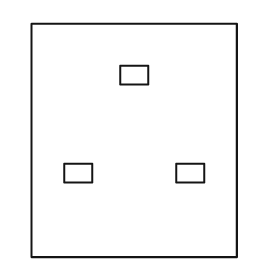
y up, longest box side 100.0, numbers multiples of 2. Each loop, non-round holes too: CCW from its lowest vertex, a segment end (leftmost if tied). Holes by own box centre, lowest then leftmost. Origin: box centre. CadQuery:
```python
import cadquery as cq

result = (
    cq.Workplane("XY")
    .moveTo(-44.0, -50.0)
    .lineTo(44.0, -50.0)
    .lineTo(44.0, 50.0)
    .lineTo(-44.0, 50.0)
    .close()
    .moveTo(-30.0, -18.0)
    .lineTo(-18.0, -18.0)
    .lineTo(-18.0, -10.0)
    .lineTo(-30.0, -10.0)
    .close()
    .moveTo(18.0, -18.0)
    .lineTo(30.0, -18.0)
    .lineTo(30.0, -10.0)
    .lineTo(18.0, -10.0)
    .close()
    .moveTo(-6.0, 24.0)
    .lineTo(6.0, 24.0)
    .lineTo(6.0, 32.0)
    .lineTo(-6.0, 32.0)
    .close()
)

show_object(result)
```